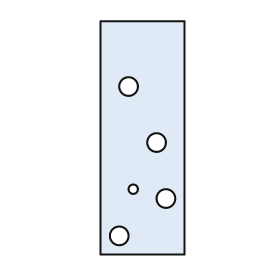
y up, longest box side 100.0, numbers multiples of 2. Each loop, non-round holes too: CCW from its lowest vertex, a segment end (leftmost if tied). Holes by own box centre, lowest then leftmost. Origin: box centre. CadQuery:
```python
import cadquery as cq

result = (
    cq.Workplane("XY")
    .moveTo(-18.0, -50.0)
    .lineTo(18.0, -50.0)
    .lineTo(18.0, 50.0)
    .lineTo(-18.0, 50.0)
    .close()
    .moveTo(-10.0, -42.0)
    .circle(4.0)
    .moveTo(10.0, -26.0)
    .circle(4.0)
    .moveTo(-4.0, -22.0)
    .circle(2.0)
    .moveTo(6.0, -2.0)
    .circle(4.0)
    .moveTo(-6.0, 22.0)
    .circle(4.0)
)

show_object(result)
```